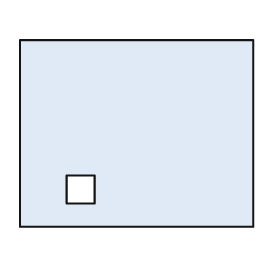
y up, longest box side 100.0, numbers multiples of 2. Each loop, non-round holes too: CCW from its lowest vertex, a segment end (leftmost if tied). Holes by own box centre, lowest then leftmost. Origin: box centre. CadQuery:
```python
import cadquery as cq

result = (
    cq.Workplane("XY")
    .moveTo(-50.0, -40.0)
    .lineTo(50.0, -40.0)
    .lineTo(50.0, 40.0)
    .lineTo(-50.0, 40.0)
    .close()
    .moveTo(-30.0, -30.0)
    .lineTo(-18.0, -30.0)
    .lineTo(-18.0, -18.0)
    .lineTo(-30.0, -18.0)
    .close()
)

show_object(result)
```